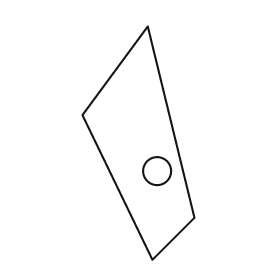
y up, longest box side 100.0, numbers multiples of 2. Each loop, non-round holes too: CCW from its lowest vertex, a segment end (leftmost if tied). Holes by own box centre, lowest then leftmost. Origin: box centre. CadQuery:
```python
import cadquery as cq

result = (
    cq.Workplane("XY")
    .moveTo(6.0, -50.0)
    .lineTo(24.0, -32.0)
    .lineTo(4.0, 50.0)
    .lineTo(-24.0, 12.0)
    .close()
    .moveTo(8.0, -12.0)
    .circle(6.0)
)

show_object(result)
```